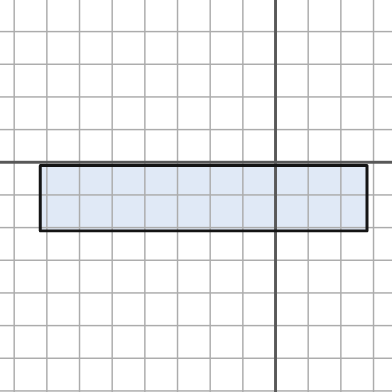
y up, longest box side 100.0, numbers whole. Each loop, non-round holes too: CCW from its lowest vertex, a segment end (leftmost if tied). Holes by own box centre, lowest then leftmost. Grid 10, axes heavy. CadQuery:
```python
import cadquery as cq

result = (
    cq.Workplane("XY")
    .moveTo(-72.0, -21.0)
    .lineTo(28.0, -21.0)
    .lineTo(28.0, -1.0)
    .lineTo(-72.0, -1.0)
    .close()
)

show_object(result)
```